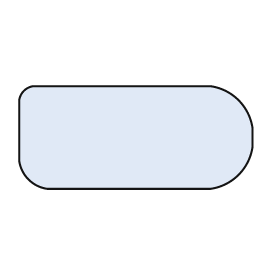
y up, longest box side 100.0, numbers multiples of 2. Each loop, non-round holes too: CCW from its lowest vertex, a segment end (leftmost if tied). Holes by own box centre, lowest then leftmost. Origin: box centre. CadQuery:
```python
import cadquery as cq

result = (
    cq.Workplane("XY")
    .moveTo(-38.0, -22.0)
    .lineTo(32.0, -22.0)
    .threePointArc((44.0, -16.0), (50.0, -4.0))
    .lineTo(50.0, 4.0)
    .threePointArc((44.0, 16.0), (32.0, 22.0))
    .lineTo(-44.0, 22.0)
    .threePointArc((-48.0, 20.0), (-50.0, 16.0))
    .lineTo(-50.0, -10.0)
    .threePointArc((-46.0, -18.0), (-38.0, -22.0))
    .close()
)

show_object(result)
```